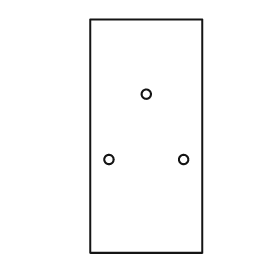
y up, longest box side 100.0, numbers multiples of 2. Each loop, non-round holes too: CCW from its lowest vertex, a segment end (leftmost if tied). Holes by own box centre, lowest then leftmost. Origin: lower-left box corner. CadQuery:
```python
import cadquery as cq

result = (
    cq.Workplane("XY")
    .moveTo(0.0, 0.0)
    .lineTo(48.0, 0.0)
    .lineTo(48.0, 100.0)
    .lineTo(0.0, 100.0)
    .close()
    .moveTo(8.0, 40.0)
    .circle(2.0)
    .moveTo(40.0, 40.0)
    .circle(2.0)
    .moveTo(24.0, 68.0)
    .circle(2.0)
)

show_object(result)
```